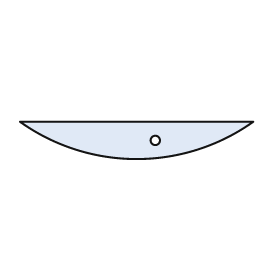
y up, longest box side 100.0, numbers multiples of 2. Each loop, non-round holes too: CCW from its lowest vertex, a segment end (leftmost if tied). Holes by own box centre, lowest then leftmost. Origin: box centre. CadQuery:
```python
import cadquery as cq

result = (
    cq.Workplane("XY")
    .moveTo(-50.0, 8.0)
    .threePointArc((0.0, -8.0), (50.0, 8.0))
    .close()
    .moveTo(8.0, 0.0)
    .circle(2.0)
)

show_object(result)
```